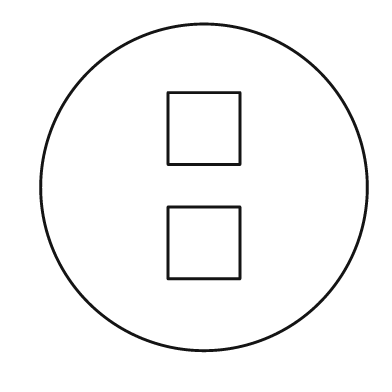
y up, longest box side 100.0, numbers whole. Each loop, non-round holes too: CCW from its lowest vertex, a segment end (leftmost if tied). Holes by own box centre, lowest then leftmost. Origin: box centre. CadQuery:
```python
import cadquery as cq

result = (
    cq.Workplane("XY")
    .moveTo(0.0, 0.0)
    .circle(50.0)
    .moveTo(-11.0, -28.0)
    .lineTo(11.0, -28.0)
    .lineTo(11.0, -6.0)
    .lineTo(-11.0, -6.0)
    .close()
    .moveTo(-11.0, 7.0)
    .lineTo(11.0, 7.0)
    .lineTo(11.0, 29.0)
    .lineTo(-11.0, 29.0)
    .close()
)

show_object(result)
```